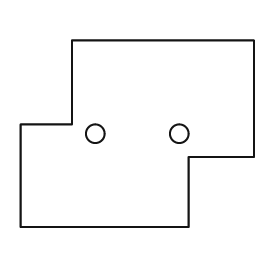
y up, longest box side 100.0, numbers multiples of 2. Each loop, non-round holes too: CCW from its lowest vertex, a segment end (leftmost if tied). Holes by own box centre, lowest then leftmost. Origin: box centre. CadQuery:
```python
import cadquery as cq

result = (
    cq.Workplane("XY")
    .moveTo(-50.0, -40.0)
    .lineTo(22.0, -40.0)
    .lineTo(22.0, -10.0)
    .lineTo(50.0, -10.0)
    .lineTo(50.0, 40.0)
    .lineTo(-28.0, 40.0)
    .lineTo(-28.0, 4.0)
    .lineTo(-50.0, 4.0)
    .close()
    .moveTo(-18.0, 0.0)
    .circle(4.0)
    .moveTo(18.0, 0.0)
    .circle(4.0)
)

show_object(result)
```